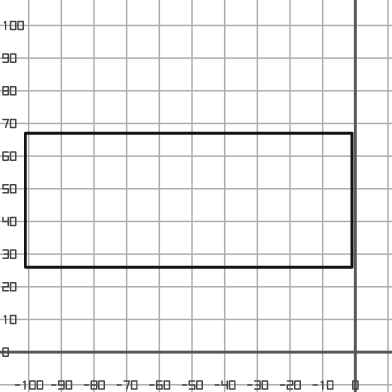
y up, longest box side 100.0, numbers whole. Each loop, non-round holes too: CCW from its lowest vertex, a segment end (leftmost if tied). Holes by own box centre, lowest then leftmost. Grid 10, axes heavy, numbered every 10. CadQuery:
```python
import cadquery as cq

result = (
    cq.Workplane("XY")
    .moveTo(-101.0, 26.0)
    .lineTo(-1.0, 26.0)
    .lineTo(-1.0, 67.0)
    .lineTo(-101.0, 67.0)
    .close()
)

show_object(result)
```